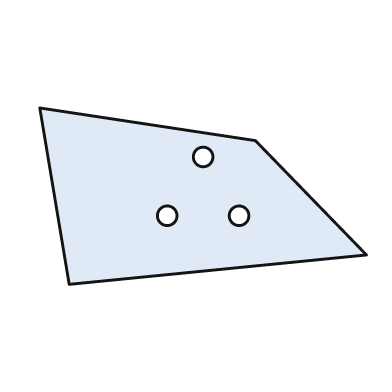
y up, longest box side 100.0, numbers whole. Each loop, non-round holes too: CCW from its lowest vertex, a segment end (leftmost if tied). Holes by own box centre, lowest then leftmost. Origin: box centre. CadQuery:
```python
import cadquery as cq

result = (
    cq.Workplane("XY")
    .moveTo(-41.0, -27.0)
    .lineTo(50.0, -18.0)
    .lineTo(16.0, 17.0)
    .lineTo(-50.0, 27.0)
    .close()
    .moveTo(-11.0, -6.0)
    .circle(3.0)
    .moveTo(11.0, -6.0)
    .circle(3.0)
    .moveTo(0.0, 12.0)
    .circle(3.0)
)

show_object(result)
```